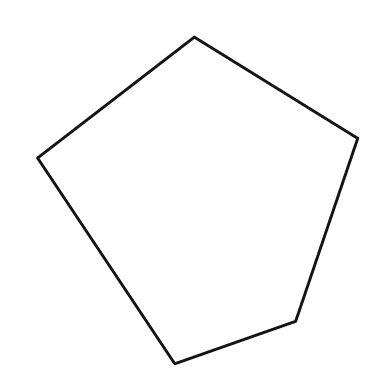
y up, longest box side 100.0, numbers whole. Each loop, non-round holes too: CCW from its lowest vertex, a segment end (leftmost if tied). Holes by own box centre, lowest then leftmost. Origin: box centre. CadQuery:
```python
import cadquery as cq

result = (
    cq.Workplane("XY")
    .moveTo(-7.0, -50.0)
    .lineTo(30.0, -37.0)
    .lineTo(49.0, 19.0)
    .lineTo(-1.0, 50.0)
    .lineTo(-49.0, 13.0)
    .close()
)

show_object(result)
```